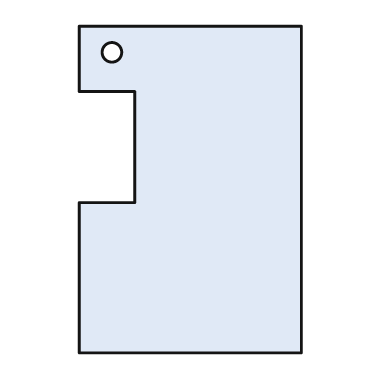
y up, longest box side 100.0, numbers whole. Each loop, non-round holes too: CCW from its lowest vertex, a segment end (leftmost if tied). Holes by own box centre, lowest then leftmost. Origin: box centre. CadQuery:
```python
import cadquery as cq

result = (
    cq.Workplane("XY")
    .moveTo(-34.0, -50.0)
    .lineTo(34.0, -50.0)
    .lineTo(34.0, 50.0)
    .lineTo(-34.0, 50.0)
    .lineTo(-34.0, 30.0)
    .lineTo(-17.0, 30.0)
    .lineTo(-17.0, -4.0)
    .lineTo(-34.0, -4.0)
    .close()
    .moveTo(-24.0, 42.0)
    .circle(3.0)
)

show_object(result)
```